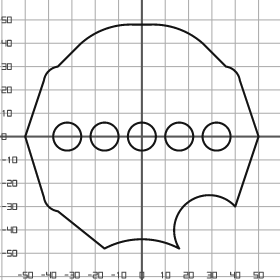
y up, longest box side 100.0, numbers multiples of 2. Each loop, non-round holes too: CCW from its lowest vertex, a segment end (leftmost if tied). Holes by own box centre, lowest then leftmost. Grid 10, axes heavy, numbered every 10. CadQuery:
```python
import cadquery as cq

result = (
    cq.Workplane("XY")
    .moveTo(-16.0, -48.0)
    .threePointArc((0.0, -44.0), (16.0, -48.0))
    .threePointArc((20.0, -28.0), (40.0, -30.0))
    .lineTo(50.0, 0.0)
    .lineTo(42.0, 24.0)
    .threePointArc((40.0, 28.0), (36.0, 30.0))
    .lineTo(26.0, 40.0)
    .threePointArc((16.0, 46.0), (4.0, 48.0))
    .lineTo(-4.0, 48.0)
    .threePointArc((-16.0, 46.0), (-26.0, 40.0))
    .lineTo(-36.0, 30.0)
    .threePointArc((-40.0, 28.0), (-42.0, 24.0))
    .lineTo(-50.0, 0.0)
    .lineTo(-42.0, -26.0)
    .threePointArc((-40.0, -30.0), (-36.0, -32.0))
    .close()
    .moveTo(-32.0, 0.0)
    .circle(6.0)
    .moveTo(-16.0, 0.0)
    .circle(6.0)
    .moveTo(0.0, 0.0)
    .circle(6.0)
    .moveTo(16.0, 0.0)
    .circle(6.0)
    .moveTo(32.0, 0.0)
    .circle(6.0)
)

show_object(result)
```